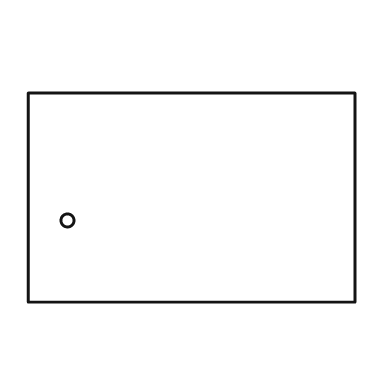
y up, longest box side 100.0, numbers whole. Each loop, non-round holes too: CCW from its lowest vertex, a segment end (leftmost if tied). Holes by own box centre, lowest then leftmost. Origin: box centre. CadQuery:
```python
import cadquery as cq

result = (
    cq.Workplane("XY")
    .moveTo(-50.0, -32.0)
    .lineTo(50.0, -32.0)
    .lineTo(50.0, 32.0)
    .lineTo(-50.0, 32.0)
    .close()
    .moveTo(-38.0, -7.0)
    .circle(2.0)
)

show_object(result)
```